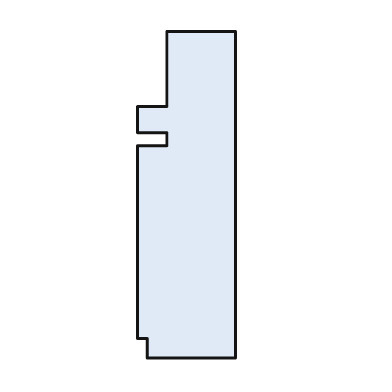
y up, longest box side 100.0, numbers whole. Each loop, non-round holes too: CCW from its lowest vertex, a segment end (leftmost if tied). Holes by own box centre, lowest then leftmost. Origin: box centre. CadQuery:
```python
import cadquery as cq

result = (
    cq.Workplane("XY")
    .moveTo(-12.0, -50.0)
    .lineTo(15.0, -50.0)
    .lineTo(15.0, 50.0)
    .lineTo(-6.0, 50.0)
    .lineTo(-6.0, 27.0)
    .lineTo(-15.0, 27.0)
    .lineTo(-15.0, 19.0)
    .lineTo(-6.0, 19.0)
    .lineTo(-6.0, 15.0)
    .lineTo(-15.0, 15.0)
    .lineTo(-15.0, -44.0)
    .lineTo(-12.0, -44.0)
    .close()
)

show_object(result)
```